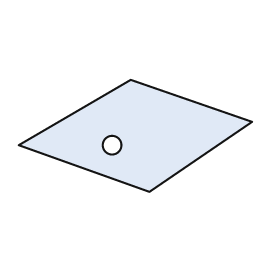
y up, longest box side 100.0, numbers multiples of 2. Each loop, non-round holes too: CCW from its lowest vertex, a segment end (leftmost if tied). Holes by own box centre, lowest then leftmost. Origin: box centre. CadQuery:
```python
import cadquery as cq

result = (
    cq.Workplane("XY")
    .moveTo(6.0, -24.0)
    .lineTo(50.0, 6.0)
    .lineTo(-2.0, 24.0)
    .lineTo(-50.0, -4.0)
    .close()
    .moveTo(-10.0, -4.0)
    .circle(4.0)
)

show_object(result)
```